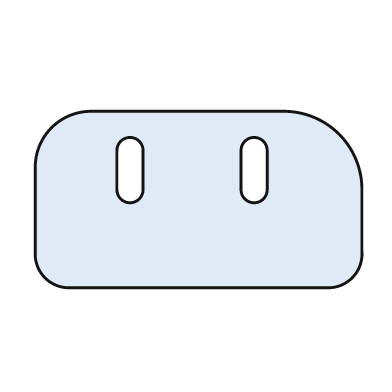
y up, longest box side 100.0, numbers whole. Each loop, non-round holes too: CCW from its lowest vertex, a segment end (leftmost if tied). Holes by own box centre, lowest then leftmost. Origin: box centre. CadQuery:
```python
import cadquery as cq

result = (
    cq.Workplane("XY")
    .moveTo(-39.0, -27.0)
    .lineTo(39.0, -27.0)
    .threePointArc((47.0, -24.0), (50.0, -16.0))
    .lineTo(50.0, 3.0)
    .threePointArc((43.0, 20.0), (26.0, 27.0))
    .lineTo(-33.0, 27.0)
    .threePointArc((-45.0, 22.0), (-50.0, 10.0))
    .lineTo(-50.0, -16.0)
    .threePointArc((-47.0, -24.0), (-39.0, -27.0))
    .close()
    .moveTo(-25.0, 3.0)
    .threePointArc((-21.0, -1.0), (-17.0, 3.0))
    .lineTo(-17.0, 15.0)
    .threePointArc((-21.0, 19.0), (-25.0, 15.0))
    .close()
    .moveTo(13.0, 3.0)
    .threePointArc((17.0, -1.0), (21.0, 3.0))
    .lineTo(21.0, 15.0)
    .threePointArc((17.0, 19.0), (13.0, 15.0))
    .close()
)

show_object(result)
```